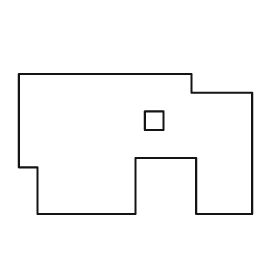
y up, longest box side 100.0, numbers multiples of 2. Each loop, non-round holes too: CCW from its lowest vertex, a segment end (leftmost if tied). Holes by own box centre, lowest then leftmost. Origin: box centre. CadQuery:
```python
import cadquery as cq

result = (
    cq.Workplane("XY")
    .moveTo(-42.0, -30.0)
    .lineTo(0.0, -30.0)
    .lineTo(0.0, -6.0)
    .lineTo(26.0, -6.0)
    .lineTo(26.0, -30.0)
    .lineTo(50.0, -30.0)
    .lineTo(50.0, 22.0)
    .lineTo(24.0, 22.0)
    .lineTo(24.0, 30.0)
    .lineTo(-50.0, 30.0)
    .lineTo(-50.0, -10.0)
    .lineTo(-42.0, -10.0)
    .close()
    .moveTo(4.0, 6.0)
    .lineTo(12.0, 6.0)
    .lineTo(12.0, 14.0)
    .lineTo(4.0, 14.0)
    .close()
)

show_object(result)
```